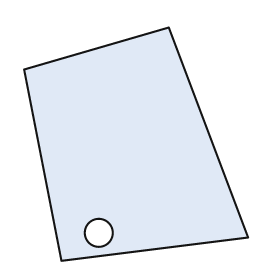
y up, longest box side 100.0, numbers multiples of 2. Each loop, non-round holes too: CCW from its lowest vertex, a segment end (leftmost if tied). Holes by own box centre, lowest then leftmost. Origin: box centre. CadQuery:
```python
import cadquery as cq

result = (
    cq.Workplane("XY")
    .moveTo(-32.0, -50.0)
    .lineTo(48.0, -40.0)
    .lineTo(14.0, 50.0)
    .lineTo(-48.0, 32.0)
    .close()
    .moveTo(-16.0, -38.0)
    .circle(6.0)
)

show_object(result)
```